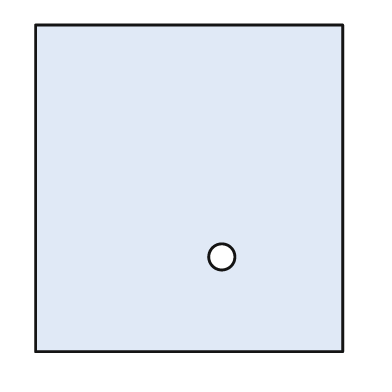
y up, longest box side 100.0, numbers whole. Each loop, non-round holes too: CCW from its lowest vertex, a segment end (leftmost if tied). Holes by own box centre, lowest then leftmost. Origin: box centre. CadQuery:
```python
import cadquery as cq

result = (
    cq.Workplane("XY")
    .moveTo(-47.0, -50.0)
    .lineTo(47.0, -50.0)
    .lineTo(47.0, 50.0)
    .lineTo(-47.0, 50.0)
    .close()
    .moveTo(10.0, -21.0)
    .circle(4.0)
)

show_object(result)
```